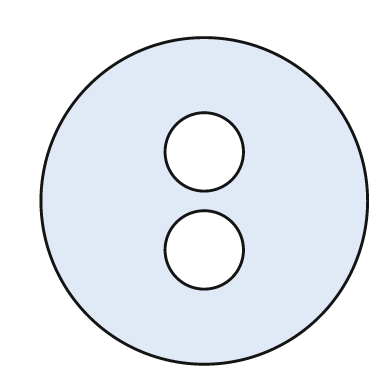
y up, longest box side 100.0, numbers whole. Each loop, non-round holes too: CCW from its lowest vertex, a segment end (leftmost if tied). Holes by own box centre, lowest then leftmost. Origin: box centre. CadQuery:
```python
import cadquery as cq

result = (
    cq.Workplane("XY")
    .moveTo(0.0, 0.0)
    .circle(50.0)
    .moveTo(0.0, -15.0)
    .circle(12.0)
    .moveTo(0.0, 15.0)
    .circle(12.0)
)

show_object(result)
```